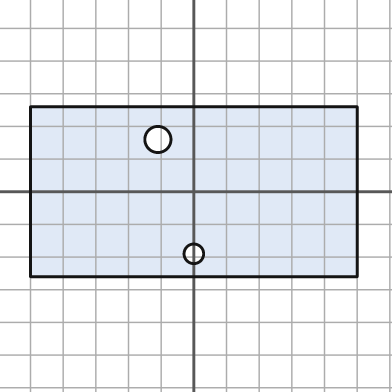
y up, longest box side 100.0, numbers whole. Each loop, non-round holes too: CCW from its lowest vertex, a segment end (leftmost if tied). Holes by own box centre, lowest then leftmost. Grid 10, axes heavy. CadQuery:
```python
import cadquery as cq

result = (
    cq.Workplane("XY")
    .moveTo(-50.0, -26.0)
    .lineTo(50.0, -26.0)
    .lineTo(50.0, 26.0)
    .lineTo(-50.0, 26.0)
    .close()
    .moveTo(0.0, -19.0)
    .circle(3.0)
    .moveTo(-11.0, 16.0)
    .circle(4.0)
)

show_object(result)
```